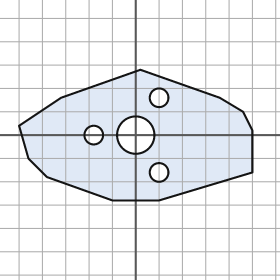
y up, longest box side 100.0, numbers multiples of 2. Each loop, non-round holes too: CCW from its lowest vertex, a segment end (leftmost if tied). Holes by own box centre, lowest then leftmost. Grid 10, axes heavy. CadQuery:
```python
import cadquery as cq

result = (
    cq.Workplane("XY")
    .moveTo(-10.0, -28.0)
    .lineTo(10.0, -28.0)
    .lineTo(50.0, -16.0)
    .lineTo(50.0, 2.0)
    .lineTo(46.0, 10.0)
    .lineTo(36.0, 16.0)
    .lineTo(2.0, 28.0)
    .lineTo(-32.0, 16.0)
    .lineTo(-50.0, 4.0)
    .lineTo(-46.0, -10.0)
    .lineTo(-38.0, -18.0)
    .close()
    .moveTo(10.0, -16.0)
    .circle(4.0)
    .moveTo(-18.0, 0.0)
    .circle(4.0)
    .moveTo(0.0, 0.0)
    .circle(8.0)
    .moveTo(10.0, 16.0)
    .circle(4.0)
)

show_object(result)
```